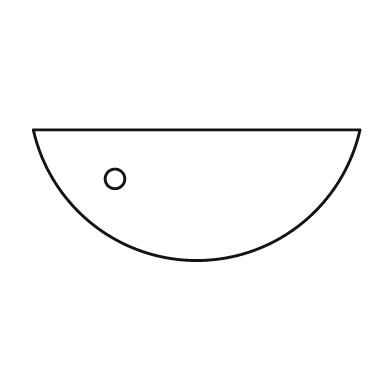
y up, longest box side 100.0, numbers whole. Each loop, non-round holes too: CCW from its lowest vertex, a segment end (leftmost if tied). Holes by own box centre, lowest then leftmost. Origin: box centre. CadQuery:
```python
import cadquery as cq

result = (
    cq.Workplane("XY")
    .moveTo(-50.0, 20.0)
    .threePointArc((0.0, -20.0), (50.0, 20.0))
    .close()
    .moveTo(-25.0, 5.0)
    .circle(3.0)
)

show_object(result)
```